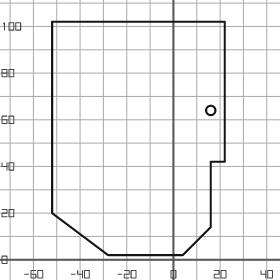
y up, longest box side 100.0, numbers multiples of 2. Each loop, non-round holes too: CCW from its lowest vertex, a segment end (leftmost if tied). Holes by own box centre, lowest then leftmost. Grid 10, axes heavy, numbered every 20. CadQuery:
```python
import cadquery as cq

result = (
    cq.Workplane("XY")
    .moveTo(-28.0, 2.0)
    .lineTo(4.0, 2.0)
    .lineTo(16.0, 14.0)
    .lineTo(16.0, 42.0)
    .lineTo(22.0, 42.0)
    .lineTo(22.0, 102.0)
    .lineTo(-52.0, 102.0)
    .lineTo(-52.0, 20.0)
    .close()
    .moveTo(16.0, 64.0)
    .circle(2.0)
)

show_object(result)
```